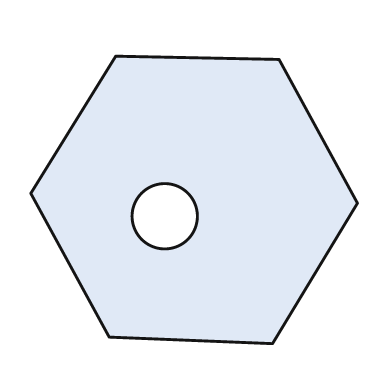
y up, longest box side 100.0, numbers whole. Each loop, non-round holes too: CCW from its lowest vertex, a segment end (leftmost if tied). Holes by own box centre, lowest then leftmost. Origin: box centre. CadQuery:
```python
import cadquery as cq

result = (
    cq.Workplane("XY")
    .moveTo(24.0, -44.0)
    .lineTo(50.0, -1.0)
    .lineTo(26.0, 43.0)
    .lineTo(-24.0, 44.0)
    .lineTo(-50.0, 2.0)
    .lineTo(-26.0, -42.0)
    .close()
    .moveTo(-9.0, -5.0)
    .circle(10.0)
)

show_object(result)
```